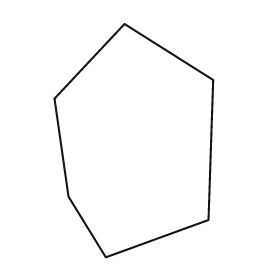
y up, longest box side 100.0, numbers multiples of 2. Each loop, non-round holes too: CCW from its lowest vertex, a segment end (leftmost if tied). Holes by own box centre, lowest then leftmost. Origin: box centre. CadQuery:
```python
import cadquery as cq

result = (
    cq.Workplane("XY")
    .moveTo(-12.0, -50.0)
    .lineTo(32.0, -34.0)
    .lineTo(34.0, 26.0)
    .lineTo(-4.0, 50.0)
    .lineTo(-34.0, 18.0)
    .lineTo(-28.0, -24.0)
    .close()
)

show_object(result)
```